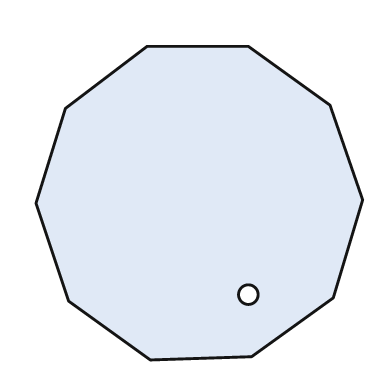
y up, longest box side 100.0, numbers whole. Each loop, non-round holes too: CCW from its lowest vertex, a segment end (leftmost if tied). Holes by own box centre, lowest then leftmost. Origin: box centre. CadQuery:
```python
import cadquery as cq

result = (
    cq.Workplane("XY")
    .moveTo(-15.0, -48.0)
    .lineTo(16.0, -47.0)
    .lineTo(41.0, -29.0)
    .lineTo(50.0, 1.0)
    .lineTo(40.0, 30.0)
    .lineTo(15.0, 48.0)
    .lineTo(-16.0, 48.0)
    .lineTo(-41.0, 29.0)
    .lineTo(-50.0, 0.0)
    .lineTo(-40.0, -30.0)
    .close()
    .moveTo(15.0, -28.0)
    .circle(3.0)
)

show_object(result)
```